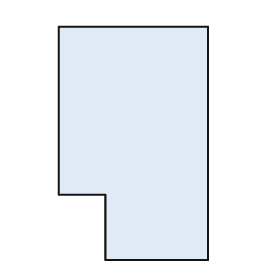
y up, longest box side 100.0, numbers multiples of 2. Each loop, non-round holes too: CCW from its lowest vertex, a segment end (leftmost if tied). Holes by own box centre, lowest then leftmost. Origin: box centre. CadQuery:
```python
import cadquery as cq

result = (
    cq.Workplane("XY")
    .moveTo(-12.0, -50.0)
    .lineTo(32.0, -50.0)
    .lineTo(32.0, 50.0)
    .lineTo(-32.0, 50.0)
    .lineTo(-32.0, -22.0)
    .lineTo(-12.0, -22.0)
    .close()
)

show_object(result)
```